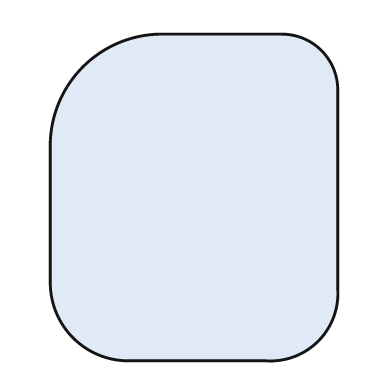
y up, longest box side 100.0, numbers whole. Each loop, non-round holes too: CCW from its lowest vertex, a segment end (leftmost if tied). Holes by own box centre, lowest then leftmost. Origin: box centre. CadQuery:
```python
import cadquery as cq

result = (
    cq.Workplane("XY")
    .moveTo(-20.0, -50.0)
    .lineTo(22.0, -50.0)
    .threePointArc((38.0, -44.0), (44.0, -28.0))
    .lineTo(44.0, 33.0)
    .threePointArc((39.0, 45.0), (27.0, 50.0))
    .lineTo(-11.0, 50.0)
    .threePointArc((-34.0, 40.0), (-44.0, 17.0))
    .lineTo(-44.0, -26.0)
    .threePointArc((-37.0, -43.0), (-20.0, -50.0))
    .close()
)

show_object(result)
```